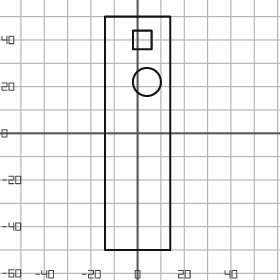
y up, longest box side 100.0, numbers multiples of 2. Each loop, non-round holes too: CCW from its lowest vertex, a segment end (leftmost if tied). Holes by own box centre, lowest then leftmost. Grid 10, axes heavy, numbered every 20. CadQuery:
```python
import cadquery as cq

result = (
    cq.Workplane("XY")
    .moveTo(-14.0, -50.0)
    .lineTo(14.0, -50.0)
    .lineTo(14.0, 50.0)
    .lineTo(-14.0, 50.0)
    .close()
    .moveTo(4.0, 22.0)
    .circle(6.0)
    .moveTo(-2.0, 36.0)
    .lineTo(6.0, 36.0)
    .lineTo(6.0, 44.0)
    .lineTo(-2.0, 44.0)
    .close()
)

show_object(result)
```